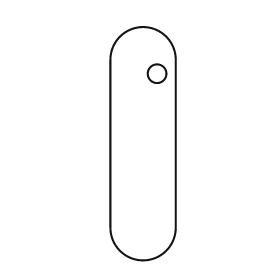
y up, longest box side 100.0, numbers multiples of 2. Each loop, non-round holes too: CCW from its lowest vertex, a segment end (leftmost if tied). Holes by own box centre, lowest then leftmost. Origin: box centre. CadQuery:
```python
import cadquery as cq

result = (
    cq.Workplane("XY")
    .moveTo(-14.0, -36.0)
    .threePointArc((0.0, -50.0), (14.0, -36.0))
    .lineTo(14.0, 36.0)
    .threePointArc((0.0, 50.0), (-14.0, 36.0))
    .close()
    .moveTo(6.0, 30.0)
    .circle(4.0)
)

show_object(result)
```